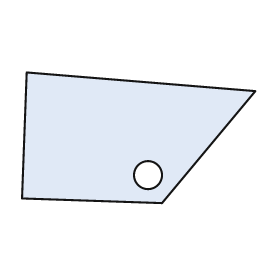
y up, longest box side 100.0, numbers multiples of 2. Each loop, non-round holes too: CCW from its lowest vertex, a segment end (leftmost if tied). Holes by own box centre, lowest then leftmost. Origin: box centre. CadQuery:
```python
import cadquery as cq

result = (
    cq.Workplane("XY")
    .moveTo(10.0, -28.0)
    .lineTo(50.0, 20.0)
    .lineTo(-48.0, 28.0)
    .lineTo(-50.0, -26.0)
    .close()
    .moveTo(4.0, -16.0)
    .circle(6.0)
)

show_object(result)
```